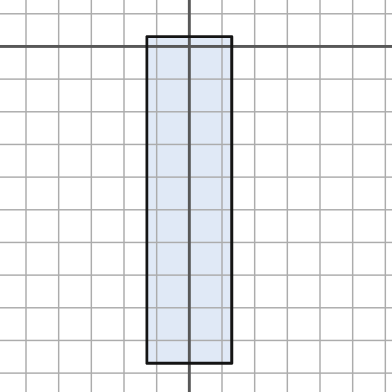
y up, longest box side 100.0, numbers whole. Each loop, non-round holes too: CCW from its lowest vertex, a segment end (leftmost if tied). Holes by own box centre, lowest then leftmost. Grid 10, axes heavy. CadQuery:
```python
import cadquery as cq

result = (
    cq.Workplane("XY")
    .moveTo(-13.0, -97.0)
    .lineTo(13.0, -97.0)
    .lineTo(13.0, 3.0)
    .lineTo(-13.0, 3.0)
    .close()
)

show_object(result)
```